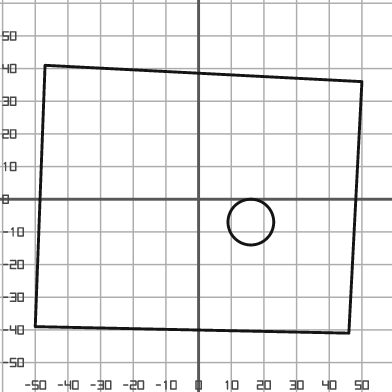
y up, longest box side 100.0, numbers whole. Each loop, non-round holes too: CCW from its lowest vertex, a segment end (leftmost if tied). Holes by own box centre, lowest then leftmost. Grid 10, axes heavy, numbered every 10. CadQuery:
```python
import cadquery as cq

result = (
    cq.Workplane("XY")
    .moveTo(46.0, -41.0)
    .lineTo(50.0, 36.0)
    .lineTo(-47.0, 41.0)
    .lineTo(-50.0, -39.0)
    .close()
    .moveTo(16.0, -7.0)
    .circle(7.0)
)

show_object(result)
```